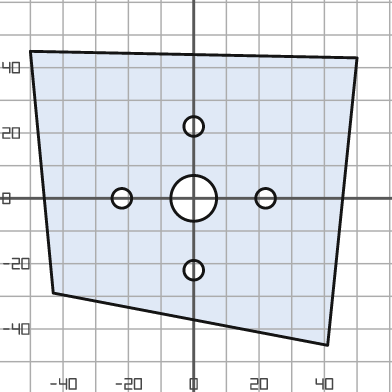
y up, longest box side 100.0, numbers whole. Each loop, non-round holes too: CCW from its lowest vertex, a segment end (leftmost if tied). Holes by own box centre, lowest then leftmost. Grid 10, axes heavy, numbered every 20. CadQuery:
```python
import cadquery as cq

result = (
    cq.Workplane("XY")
    .moveTo(41.0, -45.0)
    .lineTo(50.0, 43.0)
    .lineTo(-50.0, 45.0)
    .lineTo(-43.0, -29.0)
    .close()
    .moveTo(0.0, -22.0)
    .circle(3.0)
    .moveTo(-22.0, 0.0)
    .circle(3.0)
    .moveTo(0.0, 0.0)
    .circle(7.0)
    .moveTo(22.0, 0.0)
    .circle(3.0)
    .moveTo(0.0, 22.0)
    .circle(3.0)
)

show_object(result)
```